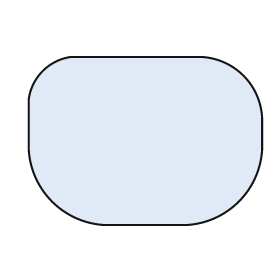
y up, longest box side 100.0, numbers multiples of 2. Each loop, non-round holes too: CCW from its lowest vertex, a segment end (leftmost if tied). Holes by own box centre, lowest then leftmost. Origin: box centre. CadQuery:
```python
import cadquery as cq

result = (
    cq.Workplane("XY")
    .moveTo(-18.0, -36.0)
    .lineTo(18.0, -36.0)
    .threePointArc((40.0, -26.0), (50.0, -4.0))
    .lineTo(50.0, 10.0)
    .threePointArc((42.0, 28.0), (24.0, 36.0))
    .lineTo(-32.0, 36.0)
    .threePointArc((-44.0, 30.0), (-50.0, 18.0))
    .lineTo(-50.0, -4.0)
    .threePointArc((-40.0, -26.0), (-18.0, -36.0))
    .close()
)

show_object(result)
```